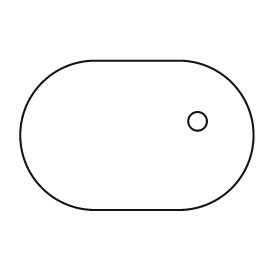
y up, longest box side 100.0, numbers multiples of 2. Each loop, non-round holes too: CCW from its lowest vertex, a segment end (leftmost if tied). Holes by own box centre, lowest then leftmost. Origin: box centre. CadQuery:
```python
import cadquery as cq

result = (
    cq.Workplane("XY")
    .moveTo(-18.0, -32.0)
    .lineTo(18.0, -32.0)
    .threePointArc((50.0, 0.0), (18.0, 32.0))
    .lineTo(-18.0, 32.0)
    .threePointArc((-50.0, 0.0), (-18.0, -32.0))
    .close()
    .moveTo(26.0, 6.0)
    .circle(4.0)
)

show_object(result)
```